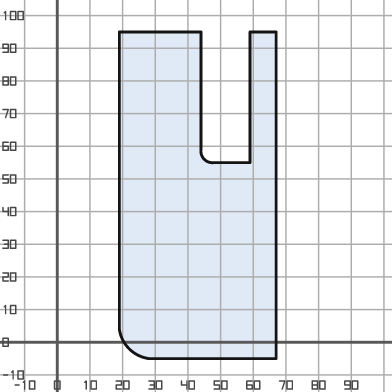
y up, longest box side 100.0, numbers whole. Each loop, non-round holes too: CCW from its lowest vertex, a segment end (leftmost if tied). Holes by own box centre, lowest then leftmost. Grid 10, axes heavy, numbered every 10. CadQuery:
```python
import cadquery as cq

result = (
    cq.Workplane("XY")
    .moveTo(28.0, -5.0)
    .lineTo(67.0, -5.0)
    .lineTo(67.0, 95.0)
    .lineTo(59.0, 95.0)
    .lineTo(59.0, 55.0)
    .lineTo(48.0, 55.0)
    .threePointArc((45.0, 56.0), (44.0, 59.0))
    .lineTo(44.0, 95.0)
    .lineTo(19.0, 95.0)
    .lineTo(19.0, 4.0)
    .threePointArc((22.0, -2.0), (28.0, -5.0))
    .close()
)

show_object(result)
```